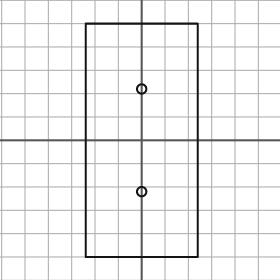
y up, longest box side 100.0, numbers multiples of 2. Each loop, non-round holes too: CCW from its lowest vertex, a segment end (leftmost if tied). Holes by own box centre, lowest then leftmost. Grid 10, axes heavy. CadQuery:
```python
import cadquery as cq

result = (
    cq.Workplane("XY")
    .moveTo(-24.0, -50.0)
    .lineTo(24.0, -50.0)
    .lineTo(24.0, 50.0)
    .lineTo(-24.0, 50.0)
    .close()
    .moveTo(0.0, -22.0)
    .circle(2.0)
    .moveTo(0.0, 22.0)
    .circle(2.0)
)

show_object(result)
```